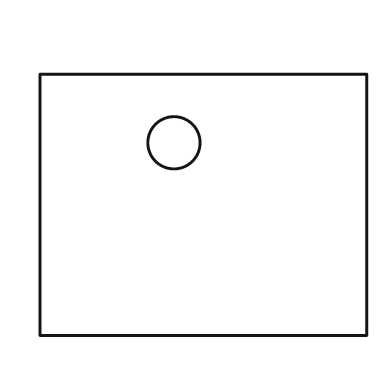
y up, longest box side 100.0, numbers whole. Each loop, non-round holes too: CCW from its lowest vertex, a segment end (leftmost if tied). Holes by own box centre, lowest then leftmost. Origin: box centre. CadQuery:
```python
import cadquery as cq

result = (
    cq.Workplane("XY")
    .moveTo(-50.0, -40.0)
    .lineTo(50.0, -40.0)
    .lineTo(50.0, 40.0)
    .lineTo(-50.0, 40.0)
    .close()
    .moveTo(-9.0, 19.0)
    .circle(8.0)
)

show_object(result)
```